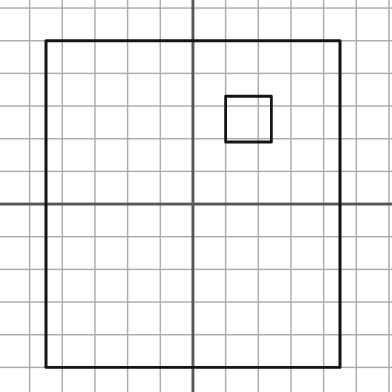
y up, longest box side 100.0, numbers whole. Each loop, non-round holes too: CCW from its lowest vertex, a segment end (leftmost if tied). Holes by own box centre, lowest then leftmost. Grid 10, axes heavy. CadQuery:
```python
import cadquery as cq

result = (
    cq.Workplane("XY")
    .moveTo(-45.0, -50.0)
    .lineTo(45.0, -50.0)
    .lineTo(45.0, 50.0)
    .lineTo(-45.0, 50.0)
    .close()
    .moveTo(10.0, 19.0)
    .lineTo(24.0, 19.0)
    .lineTo(24.0, 33.0)
    .lineTo(10.0, 33.0)
    .close()
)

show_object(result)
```